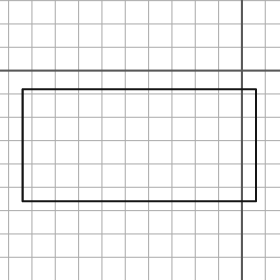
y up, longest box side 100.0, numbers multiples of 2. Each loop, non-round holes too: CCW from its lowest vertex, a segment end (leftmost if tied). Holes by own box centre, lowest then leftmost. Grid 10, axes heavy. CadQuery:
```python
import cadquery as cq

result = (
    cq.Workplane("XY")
    .moveTo(-94.0, -56.0)
    .lineTo(6.0, -56.0)
    .lineTo(6.0, -8.0)
    .lineTo(-94.0, -8.0)
    .close()
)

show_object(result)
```